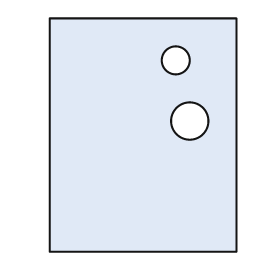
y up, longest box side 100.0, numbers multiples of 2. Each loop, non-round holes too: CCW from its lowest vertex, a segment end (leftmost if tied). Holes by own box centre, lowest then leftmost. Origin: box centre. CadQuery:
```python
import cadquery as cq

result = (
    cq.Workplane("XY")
    .moveTo(-40.0, -50.0)
    .lineTo(40.0, -50.0)
    .lineTo(40.0, 50.0)
    .lineTo(-40.0, 50.0)
    .close()
    .moveTo(20.0, 6.0)
    .circle(8.0)
    .moveTo(14.0, 32.0)
    .circle(6.0)
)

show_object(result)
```